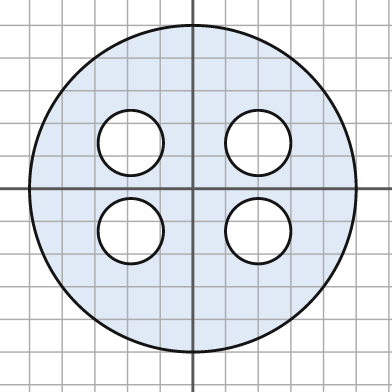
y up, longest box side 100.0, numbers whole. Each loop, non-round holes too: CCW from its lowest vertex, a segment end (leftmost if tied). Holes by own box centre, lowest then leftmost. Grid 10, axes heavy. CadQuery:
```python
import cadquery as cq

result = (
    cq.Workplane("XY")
    .moveTo(0.0, 0.0)
    .circle(50.0)
    .moveTo(-19.0, -13.0)
    .circle(10.0)
    .moveTo(20.0, -13.0)
    .circle(10.0)
    .moveTo(-19.0, 14.0)
    .circle(10.0)
    .moveTo(20.0, 14.0)
    .circle(10.0)
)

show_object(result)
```